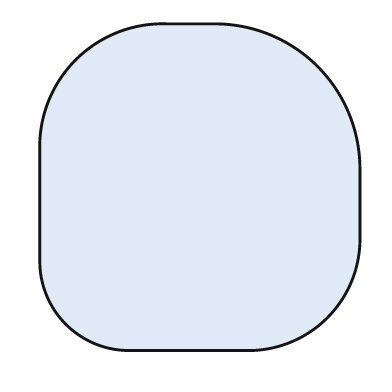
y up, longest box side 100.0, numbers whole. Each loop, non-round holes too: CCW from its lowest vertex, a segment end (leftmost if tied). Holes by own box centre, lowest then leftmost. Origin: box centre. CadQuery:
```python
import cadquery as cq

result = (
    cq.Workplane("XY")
    .moveTo(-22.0, -50.0)
    .lineTo(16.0, -50.0)
    .threePointArc((39.0, -40.0), (49.0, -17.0))
    .lineTo(49.0, 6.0)
    .threePointArc((36.0, 37.0), (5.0, 50.0))
    .lineTo(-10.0, 50.0)
    .threePointArc((-38.0, 39.0), (-49.0, 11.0))
    .lineTo(-49.0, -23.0)
    .threePointArc((-41.0, -42.0), (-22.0, -50.0))
    .close()
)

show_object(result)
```